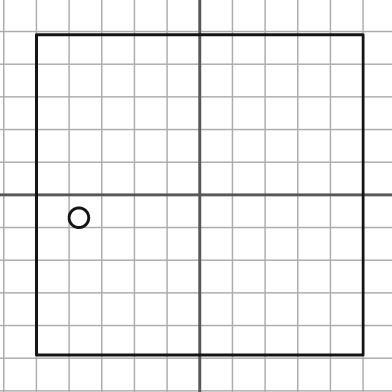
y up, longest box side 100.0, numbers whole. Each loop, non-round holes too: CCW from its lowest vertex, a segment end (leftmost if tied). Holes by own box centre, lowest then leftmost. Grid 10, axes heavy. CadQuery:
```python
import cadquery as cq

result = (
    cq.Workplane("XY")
    .moveTo(-50.0, -49.0)
    .lineTo(50.0, -49.0)
    .lineTo(50.0, 49.0)
    .lineTo(-50.0, 49.0)
    .close()
    .moveTo(-37.0, -7.0)
    .circle(3.0)
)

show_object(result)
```